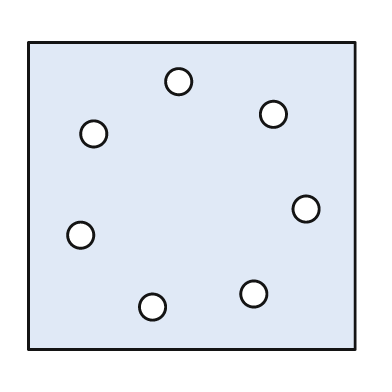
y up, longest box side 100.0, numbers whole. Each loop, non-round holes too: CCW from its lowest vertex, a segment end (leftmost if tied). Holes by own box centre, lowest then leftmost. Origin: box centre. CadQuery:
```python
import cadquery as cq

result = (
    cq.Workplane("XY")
    .moveTo(-50.0, -47.0)
    .lineTo(50.0, -47.0)
    .lineTo(50.0, 47.0)
    .lineTo(-50.0, 47.0)
    .close()
    .moveTo(-12.0, -34.0)
    .circle(4.0)
    .moveTo(19.0, -30.0)
    .circle(4.0)
    .moveTo(-34.0, -12.0)
    .circle(4.0)
    .moveTo(35.0, -4.0)
    .circle(4.0)
    .moveTo(-30.0, 19.0)
    .circle(4.0)
    .moveTo(25.0, 25.0)
    .circle(4.0)
    .moveTo(-4.0, 35.0)
    .circle(4.0)
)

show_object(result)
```